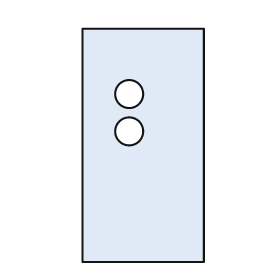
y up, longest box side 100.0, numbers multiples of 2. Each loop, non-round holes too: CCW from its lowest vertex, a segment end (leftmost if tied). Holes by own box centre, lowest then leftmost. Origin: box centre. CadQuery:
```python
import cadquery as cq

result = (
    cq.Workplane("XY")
    .moveTo(-26.0, -50.0)
    .lineTo(26.0, -50.0)
    .lineTo(26.0, 50.0)
    .lineTo(-26.0, 50.0)
    .close()
    .moveTo(-6.0, 6.0)
    .circle(6.0)
    .moveTo(-6.0, 22.0)
    .circle(6.0)
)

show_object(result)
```